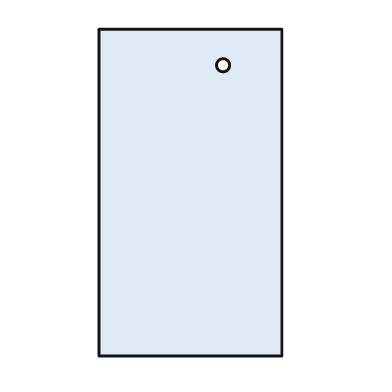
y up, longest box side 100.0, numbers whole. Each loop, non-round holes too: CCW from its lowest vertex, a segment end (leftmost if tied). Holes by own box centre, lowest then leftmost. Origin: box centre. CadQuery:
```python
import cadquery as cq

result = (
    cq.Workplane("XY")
    .moveTo(-28.0, -50.0)
    .lineTo(28.0, -50.0)
    .lineTo(28.0, 50.0)
    .lineTo(-28.0, 50.0)
    .close()
    .moveTo(10.0, 39.0)
    .circle(2.0)
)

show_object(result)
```